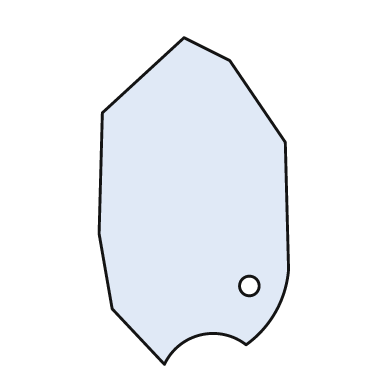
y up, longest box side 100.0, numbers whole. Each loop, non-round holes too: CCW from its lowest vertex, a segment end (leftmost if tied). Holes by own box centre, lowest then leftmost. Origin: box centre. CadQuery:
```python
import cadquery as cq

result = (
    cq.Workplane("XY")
    .moveTo(-9.0, -50.0)
    .threePointArc((2.0, -41.0), (16.0, -44.0))
    .threePointArc((25.0, -34.0), (29.0, -21.0))
    .lineTo(28.0, 18.0)
    .lineTo(11.0, 43.0)
    .lineTo(-3.0, 50.0)
    .lineTo(-28.0, 27.0)
    .lineTo(-29.0, -10.0)
    .lineTo(-25.0, -33.0)
    .close()
    .moveTo(17.0, -26.0)
    .circle(3.0)
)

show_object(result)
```